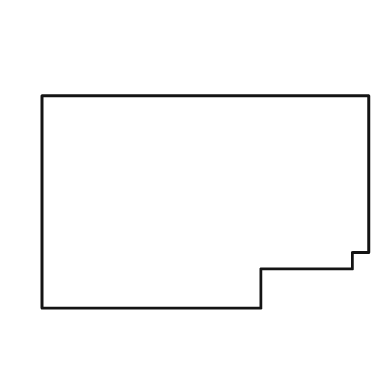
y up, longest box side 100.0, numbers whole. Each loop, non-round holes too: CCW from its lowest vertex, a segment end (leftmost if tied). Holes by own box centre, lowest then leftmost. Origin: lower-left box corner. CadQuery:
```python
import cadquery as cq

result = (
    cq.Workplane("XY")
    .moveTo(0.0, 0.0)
    .lineTo(67.0, 0.0)
    .lineTo(67.0, 12.0)
    .lineTo(95.0, 12.0)
    .lineTo(95.0, 17.0)
    .lineTo(100.0, 17.0)
    .lineTo(100.0, 65.0)
    .lineTo(0.0, 65.0)
    .close()
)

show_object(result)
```